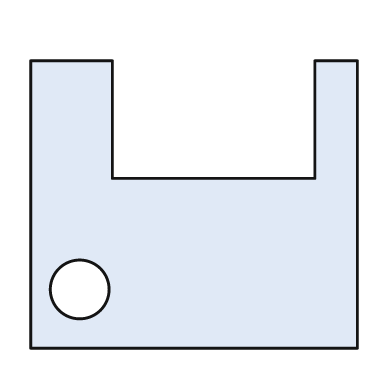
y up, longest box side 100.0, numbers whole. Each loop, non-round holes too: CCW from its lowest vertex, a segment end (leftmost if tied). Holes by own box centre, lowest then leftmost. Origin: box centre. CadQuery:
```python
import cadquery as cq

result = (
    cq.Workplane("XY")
    .moveTo(-50.0, -44.0)
    .lineTo(50.0, -44.0)
    .lineTo(50.0, 44.0)
    .lineTo(37.0, 44.0)
    .lineTo(37.0, 8.0)
    .lineTo(-25.0, 8.0)
    .lineTo(-25.0, 44.0)
    .lineTo(-50.0, 44.0)
    .close()
    .moveTo(-35.0, -26.0)
    .circle(9.0)
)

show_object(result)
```